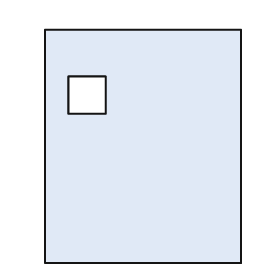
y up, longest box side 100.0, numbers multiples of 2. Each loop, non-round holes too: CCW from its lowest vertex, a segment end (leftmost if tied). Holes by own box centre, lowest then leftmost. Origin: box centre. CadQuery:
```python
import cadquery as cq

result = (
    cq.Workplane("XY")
    .moveTo(-42.0, -50.0)
    .lineTo(42.0, -50.0)
    .lineTo(42.0, 50.0)
    .lineTo(-42.0, 50.0)
    .close()
    .moveTo(-32.0, 14.0)
    .lineTo(-16.0, 14.0)
    .lineTo(-16.0, 30.0)
    .lineTo(-32.0, 30.0)
    .close()
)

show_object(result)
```